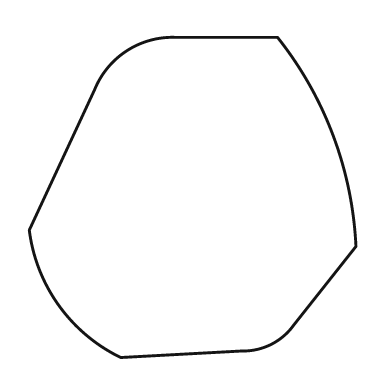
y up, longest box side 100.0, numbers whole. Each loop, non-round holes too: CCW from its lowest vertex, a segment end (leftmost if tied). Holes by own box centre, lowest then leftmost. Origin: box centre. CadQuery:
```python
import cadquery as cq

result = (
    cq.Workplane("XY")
    .moveTo(-22.0, -49.0)
    .lineTo(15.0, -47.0)
    .threePointArc((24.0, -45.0), (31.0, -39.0))
    .lineTo(50.0, -15.0)
    .threePointArc((43.0, 19.0), (26.0, 49.0))
    .lineTo(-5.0, 49.0)
    .threePointArc((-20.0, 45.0), (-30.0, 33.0))
    .lineTo(-50.0, -10.0)
    .threePointArc((-41.0, -33.0), (-22.0, -49.0))
    .close()
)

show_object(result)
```